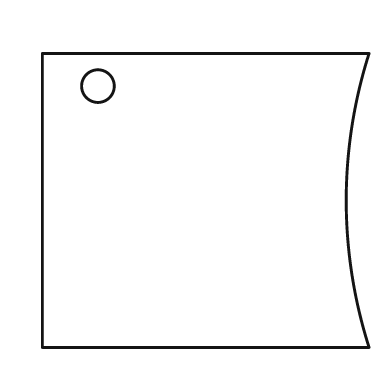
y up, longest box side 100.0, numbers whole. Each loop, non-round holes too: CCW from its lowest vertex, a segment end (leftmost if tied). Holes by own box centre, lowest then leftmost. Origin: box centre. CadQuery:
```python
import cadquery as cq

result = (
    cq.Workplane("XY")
    .moveTo(-50.0, -45.0)
    .lineTo(50.0, -45.0)
    .threePointArc((43.0, 0.0), (50.0, 45.0))
    .lineTo(-50.0, 45.0)
    .close()
    .moveTo(-33.0, 35.0)
    .circle(5.0)
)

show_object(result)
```